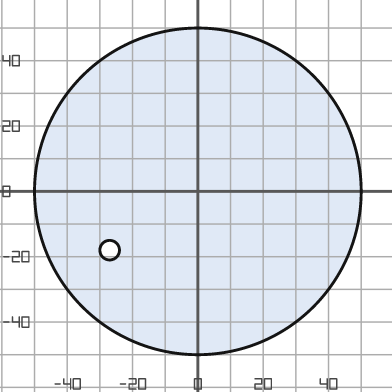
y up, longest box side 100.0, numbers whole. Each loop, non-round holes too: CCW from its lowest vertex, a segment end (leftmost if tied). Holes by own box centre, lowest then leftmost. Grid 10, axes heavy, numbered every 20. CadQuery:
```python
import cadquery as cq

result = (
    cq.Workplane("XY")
    .moveTo(0.0, 0.0)
    .circle(50.0)
    .moveTo(-27.0, -18.0)
    .circle(3.0)
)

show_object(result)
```